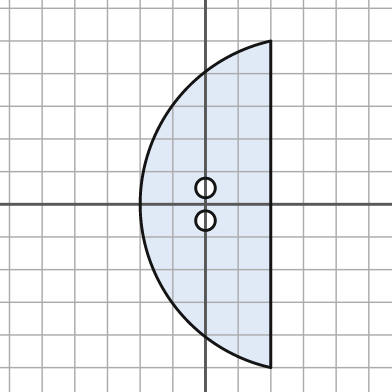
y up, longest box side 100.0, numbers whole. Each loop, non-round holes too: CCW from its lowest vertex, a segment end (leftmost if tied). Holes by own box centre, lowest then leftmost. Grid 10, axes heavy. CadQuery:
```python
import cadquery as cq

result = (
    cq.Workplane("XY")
    .moveTo(20.0, -50.0)
    .lineTo(20.0, 50.0)
    .threePointArc((-20.0, 0.0), (20.0, -50.0))
    .close()
    .moveTo(0.0, -5.0)
    .circle(3.0)
    .moveTo(0.0, 5.0)
    .circle(3.0)
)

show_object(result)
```